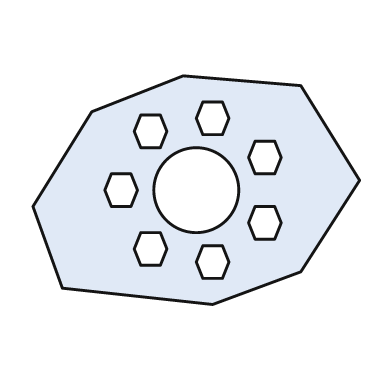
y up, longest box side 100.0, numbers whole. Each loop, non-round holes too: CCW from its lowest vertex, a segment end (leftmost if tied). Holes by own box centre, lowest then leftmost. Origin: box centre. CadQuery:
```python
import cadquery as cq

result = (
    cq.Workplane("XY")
    .moveTo(5.0, -35.0)
    .lineTo(32.0, -25.0)
    .lineTo(50.0, 3.0)
    .lineTo(32.0, 32.0)
    .lineTo(-4.0, 35.0)
    .lineTo(-32.0, 24.0)
    .lineTo(-50.0, -5.0)
    .lineTo(-41.0, -30.0)
    .close()
    .moveTo(2.0, -27.0)
    .lineTo(8.0, -27.0)
    .lineTo(10.0, -22.0)
    .lineTo(8.0, -17.0)
    .lineTo(2.0, -17.0)
    .lineTo(0.0, -22.0)
    .close()
    .moveTo(-17.0, -23.0)
    .lineTo(-11.0, -23.0)
    .lineTo(-9.0, -18.0)
    .lineTo(-11.0, -13.0)
    .lineTo(-17.0, -13.0)
    .lineTo(-19.0, -18.0)
    .close()
    .moveTo(18.0, -15.0)
    .lineTo(24.0, -15.0)
    .lineTo(26.0, -10.0)
    .lineTo(24.0, -5.0)
    .lineTo(18.0, -5.0)
    .lineTo(16.0, -10.0)
    .close()
    .moveTo(-26.0, -5.0)
    .lineTo(-20.0, -5.0)
    .lineTo(-18.0, 0.0)
    .lineTo(-20.0, 5.0)
    .lineTo(-26.0, 5.0)
    .lineTo(-28.0, 0.0)
    .close()
    .moveTo(0.0, 0.0)
    .circle(13.0)
    .moveTo(18.0, 5.0)
    .lineTo(24.0, 5.0)
    .lineTo(26.0, 10.0)
    .lineTo(24.0, 15.0)
    .lineTo(18.0, 15.0)
    .lineTo(16.0, 10.0)
    .close()
    .moveTo(-17.0, 13.0)
    .lineTo(-11.0, 13.0)
    .lineTo(-9.0, 18.0)
    .lineTo(-11.0, 23.0)
    .lineTo(-17.0, 23.0)
    .lineTo(-19.0, 18.0)
    .close()
    .moveTo(2.0, 17.0)
    .lineTo(8.0, 17.0)
    .lineTo(10.0, 22.0)
    .lineTo(8.0, 27.0)
    .lineTo(2.0, 27.0)
    .lineTo(0.0, 22.0)
    .close()
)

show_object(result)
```